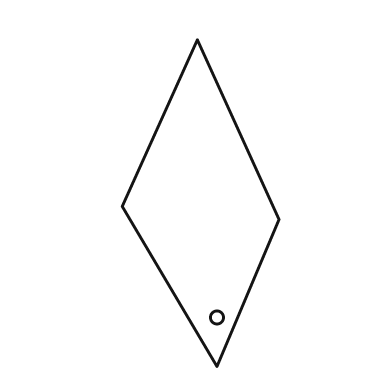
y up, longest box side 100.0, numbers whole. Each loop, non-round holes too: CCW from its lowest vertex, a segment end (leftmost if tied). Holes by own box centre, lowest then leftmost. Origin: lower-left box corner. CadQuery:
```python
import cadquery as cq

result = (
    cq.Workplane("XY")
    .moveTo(29.0, 0.0)
    .lineTo(48.0, 45.0)
    .lineTo(23.0, 100.0)
    .lineTo(0.0, 49.0)
    .close()
    .moveTo(29.0, 15.0)
    .circle(2.0)
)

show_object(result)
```